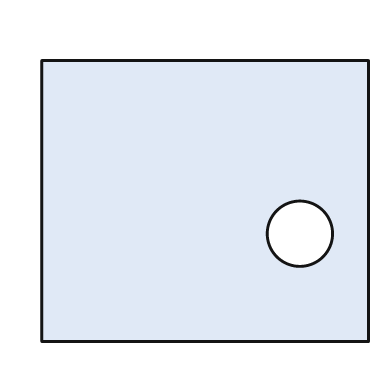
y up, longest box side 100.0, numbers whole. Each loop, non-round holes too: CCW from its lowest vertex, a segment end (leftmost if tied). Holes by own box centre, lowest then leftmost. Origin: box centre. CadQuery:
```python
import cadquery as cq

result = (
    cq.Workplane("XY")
    .moveTo(-50.0, -43.0)
    .lineTo(50.0, -43.0)
    .lineTo(50.0, 43.0)
    .lineTo(-50.0, 43.0)
    .close()
    .moveTo(29.0, -10.0)
    .circle(10.0)
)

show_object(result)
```